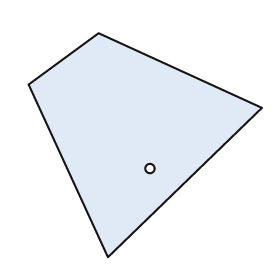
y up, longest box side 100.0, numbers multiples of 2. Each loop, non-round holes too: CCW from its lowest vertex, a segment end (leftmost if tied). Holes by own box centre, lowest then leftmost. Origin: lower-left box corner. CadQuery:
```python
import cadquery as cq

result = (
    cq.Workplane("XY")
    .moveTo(34.0, 0.0)
    .lineTo(100.0, 64.0)
    .lineTo(30.0, 96.0)
    .lineTo(0.0, 74.0)
    .close()
    .moveTo(52.0, 38.0)
    .circle(2.0)
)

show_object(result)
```